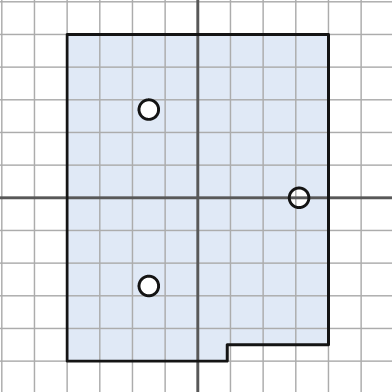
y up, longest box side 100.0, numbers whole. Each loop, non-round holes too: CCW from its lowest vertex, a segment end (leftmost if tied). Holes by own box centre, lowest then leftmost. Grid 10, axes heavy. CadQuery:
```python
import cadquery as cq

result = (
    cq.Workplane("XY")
    .moveTo(-40.0, -50.0)
    .lineTo(9.0, -50.0)
    .lineTo(9.0, -45.0)
    .lineTo(40.0, -45.0)
    .lineTo(40.0, 50.0)
    .lineTo(-40.0, 50.0)
    .close()
    .moveTo(-15.0, -27.0)
    .circle(3.0)
    .moveTo(31.0, 0.0)
    .circle(3.0)
    .moveTo(-15.0, 27.0)
    .circle(3.0)
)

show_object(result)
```